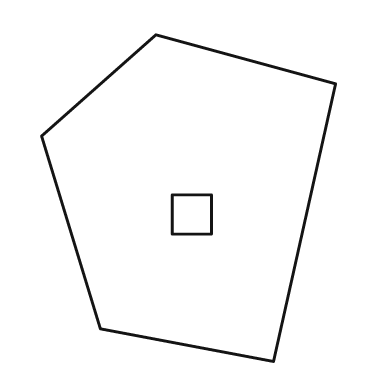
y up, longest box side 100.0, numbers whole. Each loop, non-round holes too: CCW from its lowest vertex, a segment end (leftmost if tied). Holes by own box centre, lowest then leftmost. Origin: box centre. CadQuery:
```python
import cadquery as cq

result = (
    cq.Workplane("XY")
    .moveTo(26.0, -50.0)
    .lineTo(45.0, 35.0)
    .lineTo(-10.0, 50.0)
    .lineTo(-45.0, 19.0)
    .lineTo(-27.0, -40.0)
    .close()
    .moveTo(-5.0, -11.0)
    .lineTo(7.0, -11.0)
    .lineTo(7.0, 1.0)
    .lineTo(-5.0, 1.0)
    .close()
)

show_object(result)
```